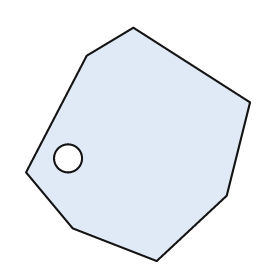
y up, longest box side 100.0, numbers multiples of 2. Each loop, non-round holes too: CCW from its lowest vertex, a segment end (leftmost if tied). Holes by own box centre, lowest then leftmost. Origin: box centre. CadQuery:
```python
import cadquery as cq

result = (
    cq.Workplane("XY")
    .moveTo(8.0, -50.0)
    .lineTo(38.0, -22.0)
    .lineTo(48.0, 18.0)
    .lineTo(-2.0, 50.0)
    .lineTo(-22.0, 38.0)
    .lineTo(-48.0, -12.0)
    .lineTo(-28.0, -36.0)
    .close()
    .moveTo(-30.0, -6.0)
    .circle(6.0)
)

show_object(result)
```